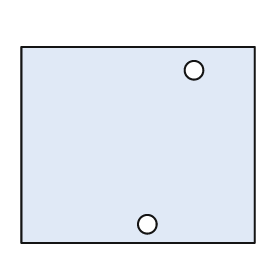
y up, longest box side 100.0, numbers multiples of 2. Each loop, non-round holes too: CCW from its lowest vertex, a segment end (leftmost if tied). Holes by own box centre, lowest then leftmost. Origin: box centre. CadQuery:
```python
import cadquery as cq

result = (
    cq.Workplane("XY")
    .moveTo(-50.0, -42.0)
    .lineTo(50.0, -42.0)
    .lineTo(50.0, 42.0)
    .lineTo(-50.0, 42.0)
    .close()
    .moveTo(4.0, -34.0)
    .circle(4.0)
    .moveTo(24.0, 32.0)
    .circle(4.0)
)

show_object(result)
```